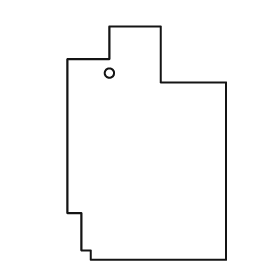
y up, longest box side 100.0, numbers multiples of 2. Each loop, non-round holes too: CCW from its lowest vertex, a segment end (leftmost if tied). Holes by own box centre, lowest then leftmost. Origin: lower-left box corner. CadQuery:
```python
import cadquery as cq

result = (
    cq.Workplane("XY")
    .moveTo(10.0, 0.0)
    .lineTo(68.0, 0.0)
    .lineTo(68.0, 76.0)
    .lineTo(40.0, 76.0)
    .lineTo(40.0, 100.0)
    .lineTo(18.0, 100.0)
    .lineTo(18.0, 86.0)
    .lineTo(0.0, 86.0)
    .lineTo(0.0, 20.0)
    .lineTo(6.0, 20.0)
    .lineTo(6.0, 4.0)
    .lineTo(10.0, 4.0)
    .close()
    .moveTo(18.0, 80.0)
    .circle(2.0)
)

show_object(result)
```